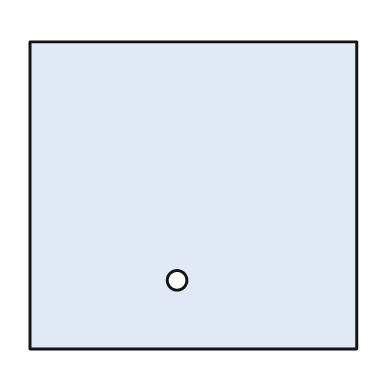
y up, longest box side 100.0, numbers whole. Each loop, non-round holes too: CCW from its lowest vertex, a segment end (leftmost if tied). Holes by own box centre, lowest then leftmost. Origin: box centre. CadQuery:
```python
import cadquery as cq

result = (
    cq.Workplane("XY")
    .moveTo(-50.0, -47.0)
    .lineTo(50.0, -47.0)
    .lineTo(50.0, 47.0)
    .lineTo(-50.0, 47.0)
    .close()
    .moveTo(-5.0, -26.0)
    .circle(3.0)
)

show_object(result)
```